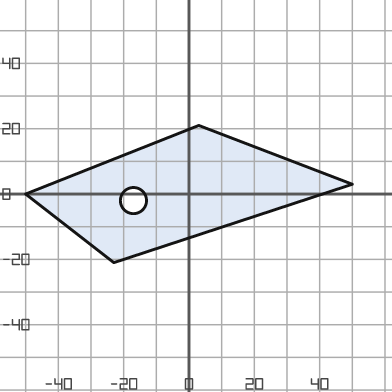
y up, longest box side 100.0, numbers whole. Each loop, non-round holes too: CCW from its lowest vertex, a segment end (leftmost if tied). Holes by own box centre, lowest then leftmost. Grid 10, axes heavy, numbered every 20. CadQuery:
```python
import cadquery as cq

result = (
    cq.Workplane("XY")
    .moveTo(-23.0, -21.0)
    .lineTo(50.0, 3.0)
    .lineTo(3.0, 21.0)
    .lineTo(-50.0, 0.0)
    .close()
    .moveTo(-17.0, -2.0)
    .circle(4.0)
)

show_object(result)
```